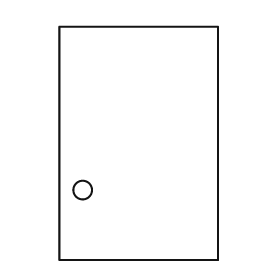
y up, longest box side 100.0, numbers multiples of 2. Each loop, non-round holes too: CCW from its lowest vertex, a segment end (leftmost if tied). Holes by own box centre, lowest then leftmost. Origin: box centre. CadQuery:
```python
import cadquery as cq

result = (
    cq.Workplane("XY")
    .moveTo(-34.0, -50.0)
    .lineTo(34.0, -50.0)
    .lineTo(34.0, 50.0)
    .lineTo(-34.0, 50.0)
    .close()
    .moveTo(-24.0, -20.0)
    .circle(4.0)
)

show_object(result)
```